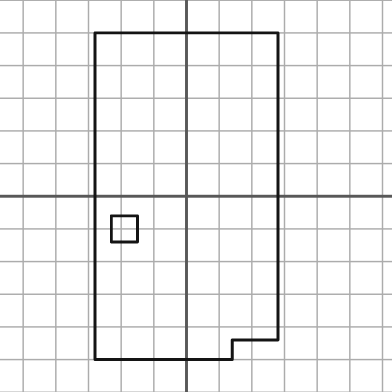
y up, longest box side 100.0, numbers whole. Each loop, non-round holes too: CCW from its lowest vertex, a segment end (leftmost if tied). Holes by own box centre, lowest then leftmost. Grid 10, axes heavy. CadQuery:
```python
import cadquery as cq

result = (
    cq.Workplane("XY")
    .moveTo(-28.0, -50.0)
    .lineTo(14.0, -50.0)
    .lineTo(14.0, -44.0)
    .lineTo(28.0, -44.0)
    .lineTo(28.0, 50.0)
    .lineTo(-28.0, 50.0)
    .close()
    .moveTo(-23.0, -14.0)
    .lineTo(-15.0, -14.0)
    .lineTo(-15.0, -6.0)
    .lineTo(-23.0, -6.0)
    .close()
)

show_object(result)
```